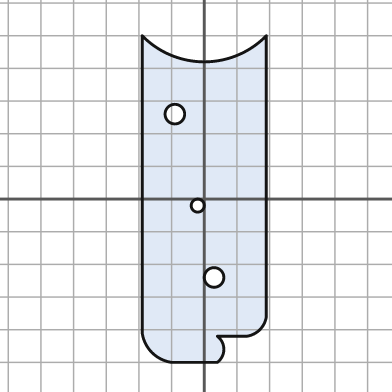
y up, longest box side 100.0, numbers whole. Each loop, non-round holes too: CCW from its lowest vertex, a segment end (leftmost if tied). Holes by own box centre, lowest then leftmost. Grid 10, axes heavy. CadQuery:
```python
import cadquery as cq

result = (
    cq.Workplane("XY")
    .moveTo(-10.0, -50.0)
    .lineTo(4.0, -50.0)
    .threePointArc((6.0, -46.0), (4.0, -42.0))
    .lineTo(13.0, -42.0)
    .threePointArc((17.0, -40.0), (19.0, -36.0))
    .lineTo(19.0, 50.0)
    .threePointArc((0.0, 42.0), (-19.0, 50.0))
    .lineTo(-19.0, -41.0)
    .threePointArc((-16.0, -47.0), (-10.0, -50.0))
    .close()
    .moveTo(3.0, -24.0)
    .circle(3.0)
    .moveTo(-2.0, -2.0)
    .circle(2.0)
    .moveTo(-9.0, 26.0)
    .circle(3.0)
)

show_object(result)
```